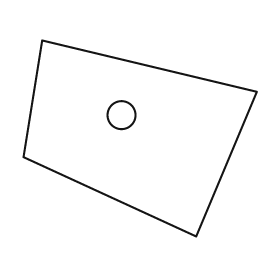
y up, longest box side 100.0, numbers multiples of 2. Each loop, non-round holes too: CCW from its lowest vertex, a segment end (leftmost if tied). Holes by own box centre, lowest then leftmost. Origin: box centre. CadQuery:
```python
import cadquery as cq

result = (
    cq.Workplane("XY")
    .moveTo(24.0, -42.0)
    .lineTo(50.0, 20.0)
    .lineTo(-42.0, 42.0)
    .lineTo(-50.0, -8.0)
    .close()
    .moveTo(-8.0, 10.0)
    .circle(6.0)
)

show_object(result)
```